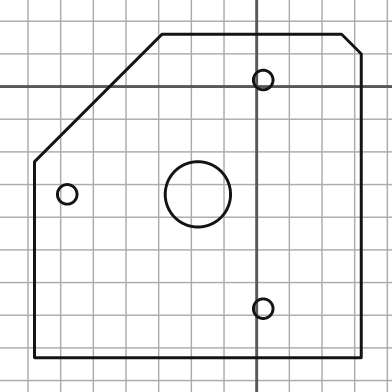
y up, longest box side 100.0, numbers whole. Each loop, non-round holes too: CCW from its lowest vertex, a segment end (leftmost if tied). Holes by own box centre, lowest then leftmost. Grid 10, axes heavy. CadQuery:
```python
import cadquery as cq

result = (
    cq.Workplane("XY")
    .moveTo(-68.0, -83.0)
    .lineTo(32.0, -83.0)
    .lineTo(32.0, 10.0)
    .lineTo(26.0, 16.0)
    .lineTo(-29.0, 16.0)
    .lineTo(-68.0, -23.0)
    .close()
    .moveTo(2.0, -68.0)
    .circle(3.0)
    .moveTo(-58.0, -33.0)
    .circle(3.0)
    .moveTo(-18.0, -33.0)
    .circle(10.0)
    .moveTo(2.0, 2.0)
    .circle(3.0)
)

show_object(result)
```